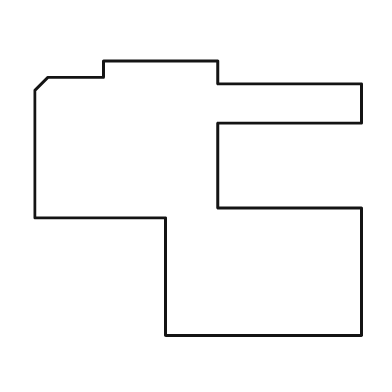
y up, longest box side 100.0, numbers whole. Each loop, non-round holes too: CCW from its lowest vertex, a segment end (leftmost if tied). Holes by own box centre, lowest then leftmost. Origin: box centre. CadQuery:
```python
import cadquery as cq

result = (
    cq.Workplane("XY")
    .moveTo(-10.0, -42.0)
    .lineTo(50.0, -42.0)
    .lineTo(50.0, -3.0)
    .lineTo(6.0, -3.0)
    .lineTo(6.0, 23.0)
    .lineTo(50.0, 23.0)
    .lineTo(50.0, 35.0)
    .lineTo(6.0, 35.0)
    .lineTo(6.0, 42.0)
    .lineTo(-29.0, 42.0)
    .lineTo(-29.0, 37.0)
    .lineTo(-46.0, 37.0)
    .lineTo(-50.0, 33.0)
    .lineTo(-50.0, -6.0)
    .lineTo(-10.0, -6.0)
    .close()
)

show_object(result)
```